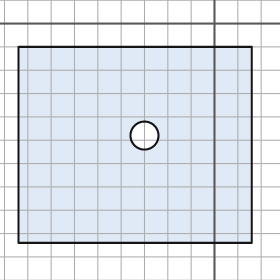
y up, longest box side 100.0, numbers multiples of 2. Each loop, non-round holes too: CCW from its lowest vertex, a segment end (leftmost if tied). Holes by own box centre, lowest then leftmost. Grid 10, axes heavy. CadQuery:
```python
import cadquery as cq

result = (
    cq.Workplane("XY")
    .moveTo(-84.0, -94.0)
    .lineTo(16.0, -94.0)
    .lineTo(16.0, -10.0)
    .lineTo(-84.0, -10.0)
    .close()
    .moveTo(-30.0, -48.0)
    .circle(6.0)
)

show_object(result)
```